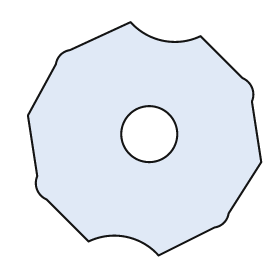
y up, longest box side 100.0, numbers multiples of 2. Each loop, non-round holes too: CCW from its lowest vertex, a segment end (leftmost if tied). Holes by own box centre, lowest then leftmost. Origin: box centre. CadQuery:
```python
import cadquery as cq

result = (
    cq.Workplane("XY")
    .moveTo(6.0, -50.0)
    .lineTo(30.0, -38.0)
    .threePointArc((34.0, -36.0), (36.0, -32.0))
    .lineTo(50.0, -10.0)
    .lineTo(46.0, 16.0)
    .threePointArc((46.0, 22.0), (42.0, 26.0))
    .lineTo(24.0, 44.0)
    .threePointArc((8.0, 42.0), (-6.0, 50.0))
    .lineTo(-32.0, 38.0)
    .threePointArc((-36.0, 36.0), (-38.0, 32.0))
    .lineTo(-50.0, 10.0)
    .lineTo(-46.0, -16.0)
    .threePointArc((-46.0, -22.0), (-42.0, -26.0))
    .lineTo(-24.0, -44.0)
    .threePointArc((-8.0, -42.0), (6.0, -50.0))
    .close()
    .moveTo(2.0, 2.0)
    .circle(12.0)
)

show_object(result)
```